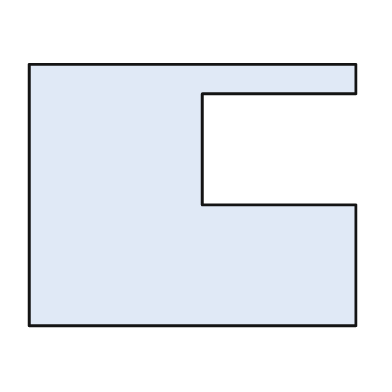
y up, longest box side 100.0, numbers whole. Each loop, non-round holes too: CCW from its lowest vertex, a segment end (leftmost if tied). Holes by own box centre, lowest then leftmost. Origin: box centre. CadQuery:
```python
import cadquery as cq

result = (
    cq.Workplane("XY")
    .moveTo(-50.0, -40.0)
    .lineTo(50.0, -40.0)
    .lineTo(50.0, -3.0)
    .lineTo(3.0, -3.0)
    .lineTo(3.0, 31.0)
    .lineTo(50.0, 31.0)
    .lineTo(50.0, 40.0)
    .lineTo(-50.0, 40.0)
    .close()
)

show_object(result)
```